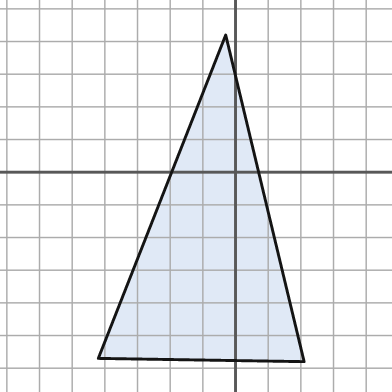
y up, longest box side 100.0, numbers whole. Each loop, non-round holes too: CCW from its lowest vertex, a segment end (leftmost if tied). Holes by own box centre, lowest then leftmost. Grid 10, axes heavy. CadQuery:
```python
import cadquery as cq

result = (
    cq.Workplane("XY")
    .moveTo(21.0, -58.0)
    .lineTo(-3.0, 42.0)
    .lineTo(-42.0, -57.0)
    .close()
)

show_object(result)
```